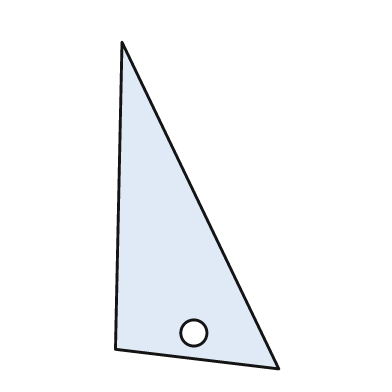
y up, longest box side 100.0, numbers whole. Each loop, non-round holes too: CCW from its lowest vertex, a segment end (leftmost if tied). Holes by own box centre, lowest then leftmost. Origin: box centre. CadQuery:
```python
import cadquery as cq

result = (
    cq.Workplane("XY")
    .moveTo(25.0, -50.0)
    .lineTo(-23.0, 50.0)
    .lineTo(-25.0, -44.0)
    .close()
    .moveTo(-1.0, -39.0)
    .circle(4.0)
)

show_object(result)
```